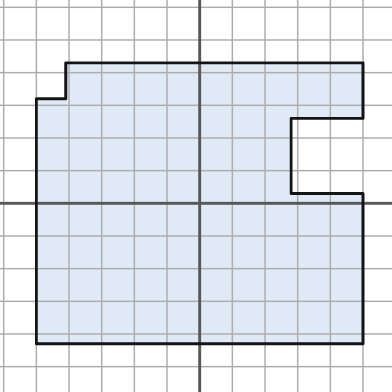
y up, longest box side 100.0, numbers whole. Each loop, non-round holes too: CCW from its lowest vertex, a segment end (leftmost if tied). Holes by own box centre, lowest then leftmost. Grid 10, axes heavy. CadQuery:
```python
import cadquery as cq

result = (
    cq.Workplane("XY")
    .moveTo(-50.0, -43.0)
    .lineTo(50.0, -43.0)
    .lineTo(50.0, 3.0)
    .lineTo(28.0, 3.0)
    .lineTo(28.0, 26.0)
    .lineTo(50.0, 26.0)
    .lineTo(50.0, 43.0)
    .lineTo(-41.0, 43.0)
    .lineTo(-41.0, 32.0)
    .lineTo(-50.0, 32.0)
    .close()
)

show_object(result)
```